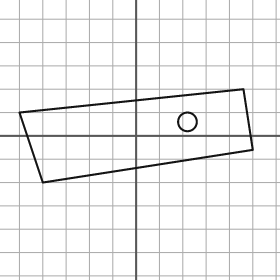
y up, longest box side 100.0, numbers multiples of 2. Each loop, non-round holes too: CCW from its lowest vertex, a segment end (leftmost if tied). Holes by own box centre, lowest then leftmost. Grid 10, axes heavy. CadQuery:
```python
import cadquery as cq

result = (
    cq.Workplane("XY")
    .moveTo(-40.0, -20.0)
    .lineTo(50.0, -6.0)
    .lineTo(46.0, 20.0)
    .lineTo(-50.0, 10.0)
    .close()
    .moveTo(22.0, 6.0)
    .circle(4.0)
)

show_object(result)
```